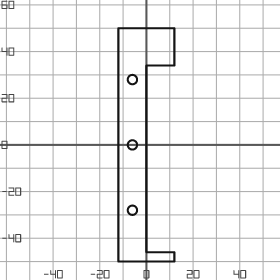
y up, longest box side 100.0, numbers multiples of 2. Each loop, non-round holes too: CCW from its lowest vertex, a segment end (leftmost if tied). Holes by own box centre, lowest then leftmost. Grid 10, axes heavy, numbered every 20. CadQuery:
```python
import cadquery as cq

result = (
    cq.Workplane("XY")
    .moveTo(-12.0, -50.0)
    .lineTo(12.0, -50.0)
    .lineTo(12.0, -46.0)
    .lineTo(0.0, -46.0)
    .lineTo(0.0, 34.0)
    .lineTo(12.0, 34.0)
    .lineTo(12.0, 50.0)
    .lineTo(-12.0, 50.0)
    .close()
    .moveTo(-6.0, -28.0)
    .circle(2.0)
    .moveTo(-6.0, 0.0)
    .circle(2.0)
    .moveTo(-6.0, 28.0)
    .circle(2.0)
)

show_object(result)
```